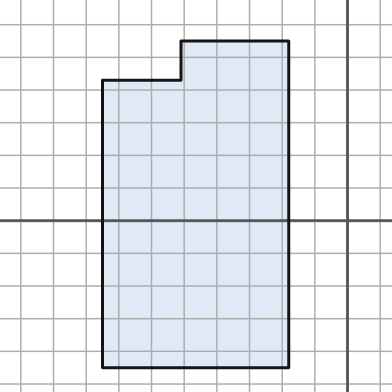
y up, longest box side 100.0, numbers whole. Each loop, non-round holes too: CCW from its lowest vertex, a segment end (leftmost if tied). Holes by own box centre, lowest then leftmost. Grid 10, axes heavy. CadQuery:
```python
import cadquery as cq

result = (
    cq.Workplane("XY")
    .moveTo(-75.0, -45.0)
    .lineTo(-18.0, -45.0)
    .lineTo(-18.0, 55.0)
    .lineTo(-51.0, 55.0)
    .lineTo(-51.0, 43.0)
    .lineTo(-75.0, 43.0)
    .close()
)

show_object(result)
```